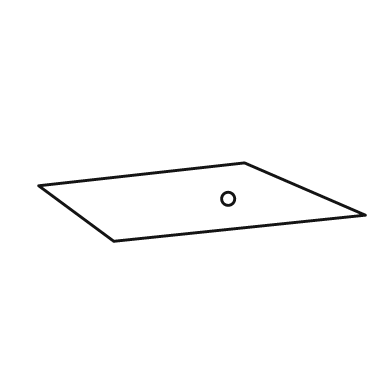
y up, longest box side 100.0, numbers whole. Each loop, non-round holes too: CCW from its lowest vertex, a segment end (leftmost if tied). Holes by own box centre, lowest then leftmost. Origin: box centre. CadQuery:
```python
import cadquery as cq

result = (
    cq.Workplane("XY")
    .moveTo(-27.0, -12.0)
    .lineTo(50.0, -4.0)
    .lineTo(13.0, 12.0)
    .lineTo(-50.0, 5.0)
    .close()
    .moveTo(8.0, 1.0)
    .circle(2.0)
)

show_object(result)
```